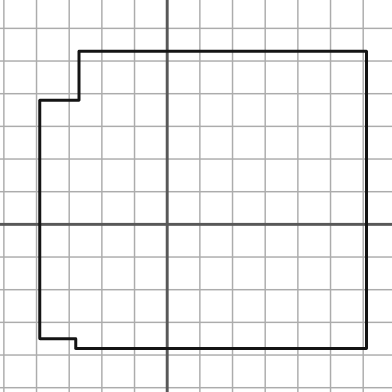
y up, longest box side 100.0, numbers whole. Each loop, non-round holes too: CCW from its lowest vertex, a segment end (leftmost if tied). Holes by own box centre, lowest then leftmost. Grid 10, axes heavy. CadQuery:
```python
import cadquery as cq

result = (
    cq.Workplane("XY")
    .moveTo(-28.0, -38.0)
    .lineTo(61.0, -38.0)
    .lineTo(61.0, 53.0)
    .lineTo(-27.0, 53.0)
    .lineTo(-27.0, 38.0)
    .lineTo(-39.0, 38.0)
    .lineTo(-39.0, -35.0)
    .lineTo(-28.0, -35.0)
    .close()
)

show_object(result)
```